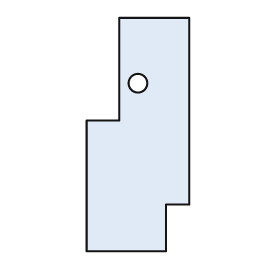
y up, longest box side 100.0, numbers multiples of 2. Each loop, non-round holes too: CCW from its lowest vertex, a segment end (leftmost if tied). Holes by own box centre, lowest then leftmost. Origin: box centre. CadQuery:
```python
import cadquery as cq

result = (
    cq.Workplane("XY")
    .moveTo(-22.0, -50.0)
    .lineTo(12.0, -50.0)
    .lineTo(12.0, -30.0)
    .lineTo(22.0, -30.0)
    .lineTo(22.0, 50.0)
    .lineTo(-8.0, 50.0)
    .lineTo(-8.0, 6.0)
    .lineTo(-22.0, 6.0)
    .close()
    .moveTo(0.0, 22.0)
    .circle(4.0)
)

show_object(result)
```